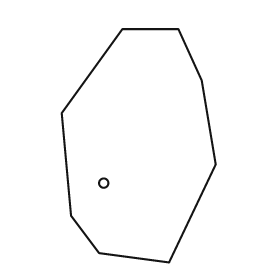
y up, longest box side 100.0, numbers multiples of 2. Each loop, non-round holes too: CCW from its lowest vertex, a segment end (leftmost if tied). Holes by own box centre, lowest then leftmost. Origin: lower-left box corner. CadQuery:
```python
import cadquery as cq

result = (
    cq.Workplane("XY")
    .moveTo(46.0, 0.0)
    .lineTo(66.0, 42.0)
    .lineTo(60.0, 78.0)
    .lineTo(50.0, 100.0)
    .lineTo(26.0, 100.0)
    .lineTo(0.0, 64.0)
    .lineTo(4.0, 20.0)
    .lineTo(16.0, 4.0)
    .close()
    .moveTo(18.0, 34.0)
    .circle(2.0)
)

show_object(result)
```